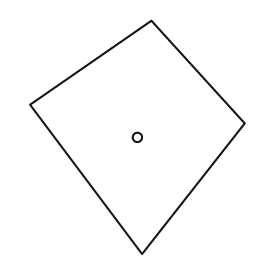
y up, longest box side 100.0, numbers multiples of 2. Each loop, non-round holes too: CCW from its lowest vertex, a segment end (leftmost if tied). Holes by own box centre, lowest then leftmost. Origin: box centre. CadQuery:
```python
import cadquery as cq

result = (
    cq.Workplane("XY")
    .moveTo(2.0, -50.0)
    .lineTo(46.0, 6.0)
    .lineTo(6.0, 50.0)
    .lineTo(-46.0, 14.0)
    .close()
    .moveTo(0.0, 0.0)
    .circle(2.0)
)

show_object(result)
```